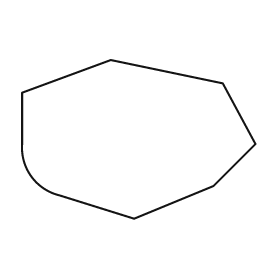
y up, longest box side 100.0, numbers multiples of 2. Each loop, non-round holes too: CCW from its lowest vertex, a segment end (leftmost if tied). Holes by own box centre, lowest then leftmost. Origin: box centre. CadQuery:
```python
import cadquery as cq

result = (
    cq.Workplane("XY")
    .moveTo(-2.0, -34.0)
    .lineTo(32.0, -20.0)
    .lineTo(50.0, -2.0)
    .lineTo(36.0, 24.0)
    .lineTo(-12.0, 34.0)
    .lineTo(-50.0, 20.0)
    .lineTo(-50.0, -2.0)
    .threePointArc((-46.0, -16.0), (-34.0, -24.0))
    .close()
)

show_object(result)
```